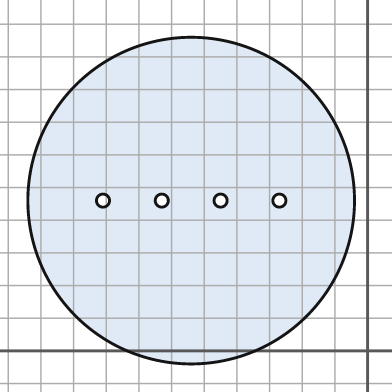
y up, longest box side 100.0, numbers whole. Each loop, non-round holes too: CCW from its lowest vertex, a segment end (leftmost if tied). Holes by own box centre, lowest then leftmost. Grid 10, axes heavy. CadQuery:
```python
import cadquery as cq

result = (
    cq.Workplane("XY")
    .moveTo(-54.0, 46.0)
    .circle(50.0)
    .moveTo(-81.0, 46.0)
    .circle(2.0)
    .moveTo(-63.0, 46.0)
    .circle(2.0)
    .moveTo(-45.0, 46.0)
    .circle(2.0)
    .moveTo(-27.0, 46.0)
    .circle(2.0)
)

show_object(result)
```